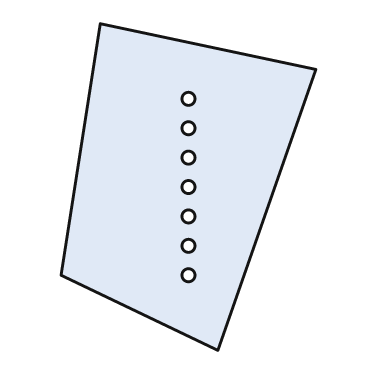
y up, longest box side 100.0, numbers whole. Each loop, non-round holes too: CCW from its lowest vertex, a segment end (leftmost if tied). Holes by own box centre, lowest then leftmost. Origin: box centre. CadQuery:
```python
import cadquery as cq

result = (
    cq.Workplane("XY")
    .moveTo(9.0, -50.0)
    .lineTo(39.0, 36.0)
    .lineTo(-27.0, 50.0)
    .lineTo(-39.0, -27.0)
    .close()
    .moveTo(0.0, -27.0)
    .circle(2.0)
    .moveTo(0.0, -18.0)
    .circle(2.0)
    .moveTo(0.0, -9.0)
    .circle(2.0)
    .moveTo(0.0, 0.0)
    .circle(2.0)
    .moveTo(0.0, 9.0)
    .circle(2.0)
    .moveTo(0.0, 18.0)
    .circle(2.0)
    .moveTo(0.0, 27.0)
    .circle(2.0)
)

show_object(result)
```